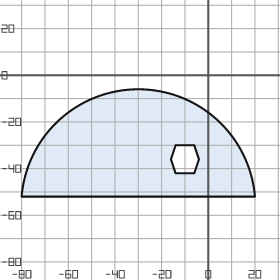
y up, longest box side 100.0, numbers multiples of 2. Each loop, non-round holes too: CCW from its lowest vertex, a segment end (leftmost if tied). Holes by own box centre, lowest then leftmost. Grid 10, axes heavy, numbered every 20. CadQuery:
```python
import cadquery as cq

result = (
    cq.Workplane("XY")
    .moveTo(-80.0, -52.0)
    .lineTo(20.0, -52.0)
    .threePointArc((-30.0, -6.0), (-80.0, -52.0))
    .close()
    .moveTo(-14.0, -42.0)
    .lineTo(-6.0, -42.0)
    .lineTo(-4.0, -36.0)
    .lineTo(-6.0, -30.0)
    .lineTo(-14.0, -30.0)
    .lineTo(-16.0, -36.0)
    .close()
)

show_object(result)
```